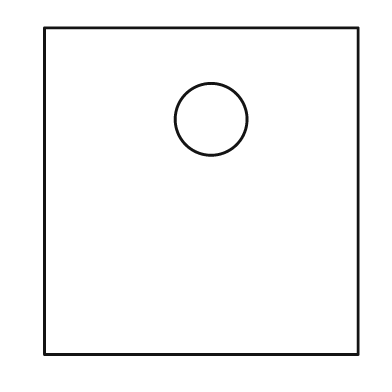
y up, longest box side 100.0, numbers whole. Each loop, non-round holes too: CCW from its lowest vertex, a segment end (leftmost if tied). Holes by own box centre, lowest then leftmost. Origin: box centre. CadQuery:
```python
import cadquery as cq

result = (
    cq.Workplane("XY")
    .moveTo(-48.0, -50.0)
    .lineTo(48.0, -50.0)
    .lineTo(48.0, 50.0)
    .lineTo(-48.0, 50.0)
    .close()
    .moveTo(3.0, 22.0)
    .circle(11.0)
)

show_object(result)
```